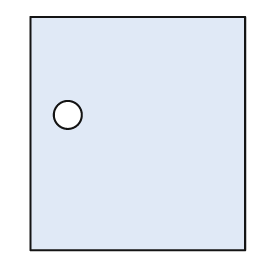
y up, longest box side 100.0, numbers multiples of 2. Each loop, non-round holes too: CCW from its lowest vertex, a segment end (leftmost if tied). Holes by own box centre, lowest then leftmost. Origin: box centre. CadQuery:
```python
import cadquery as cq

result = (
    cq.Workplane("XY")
    .moveTo(-46.0, -50.0)
    .lineTo(46.0, -50.0)
    .lineTo(46.0, 50.0)
    .lineTo(-46.0, 50.0)
    .close()
    .moveTo(-30.0, 8.0)
    .circle(6.0)
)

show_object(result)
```